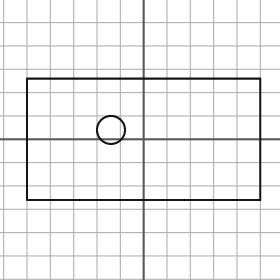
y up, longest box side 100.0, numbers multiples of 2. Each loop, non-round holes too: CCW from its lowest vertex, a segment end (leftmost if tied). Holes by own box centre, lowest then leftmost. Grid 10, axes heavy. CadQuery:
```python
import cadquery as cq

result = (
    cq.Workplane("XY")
    .moveTo(-50.0, -26.0)
    .lineTo(50.0, -26.0)
    .lineTo(50.0, 26.0)
    .lineTo(-50.0, 26.0)
    .close()
    .moveTo(-14.0, 4.0)
    .circle(6.0)
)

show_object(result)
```